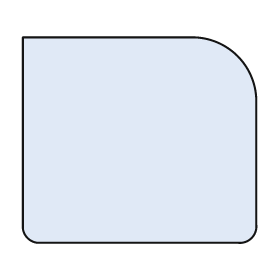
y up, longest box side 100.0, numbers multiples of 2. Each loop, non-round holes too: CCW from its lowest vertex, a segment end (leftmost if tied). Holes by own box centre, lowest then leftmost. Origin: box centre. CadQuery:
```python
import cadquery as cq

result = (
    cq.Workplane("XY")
    .moveTo(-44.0, -44.0)
    .lineTo(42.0, -44.0)
    .threePointArc((48.0, -42.0), (50.0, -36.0))
    .lineTo(50.0, 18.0)
    .threePointArc((42.0, 36.0), (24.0, 44.0))
    .lineTo(-50.0, 44.0)
    .lineTo(-50.0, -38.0)
    .threePointArc((-48.0, -42.0), (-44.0, -44.0))
    .close()
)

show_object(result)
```